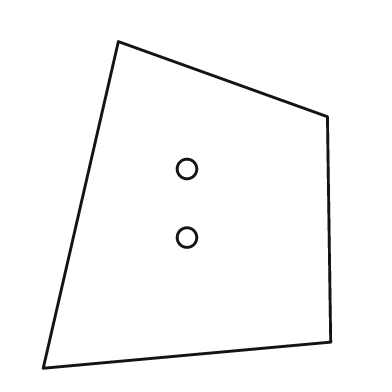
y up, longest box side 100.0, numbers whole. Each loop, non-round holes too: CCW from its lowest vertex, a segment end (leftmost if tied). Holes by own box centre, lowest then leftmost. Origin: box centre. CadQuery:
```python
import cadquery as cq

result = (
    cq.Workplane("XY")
    .moveTo(-44.0, -50.0)
    .lineTo(44.0, -42.0)
    .lineTo(43.0, 27.0)
    .lineTo(-21.0, 50.0)
    .close()
    .moveTo(0.0, -10.0)
    .circle(3.0)
    .moveTo(0.0, 11.0)
    .circle(3.0)
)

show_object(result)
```